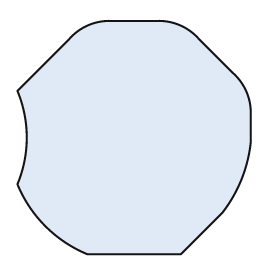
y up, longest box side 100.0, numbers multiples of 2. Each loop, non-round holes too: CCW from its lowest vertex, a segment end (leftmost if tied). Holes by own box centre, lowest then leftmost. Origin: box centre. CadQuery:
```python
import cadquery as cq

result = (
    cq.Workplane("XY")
    .moveTo(-20.0, -50.0)
    .lineTo(20.0, -50.0)
    .lineTo(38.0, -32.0)
    .threePointArc((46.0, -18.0), (50.0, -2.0))
    .lineTo(50.0, 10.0)
    .threePointArc((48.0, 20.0), (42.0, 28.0))
    .lineTo(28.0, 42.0)
    .threePointArc((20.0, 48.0), (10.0, 50.0))
    .lineTo(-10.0, 50.0)
    .threePointArc((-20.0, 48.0), (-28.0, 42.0))
    .lineTo(-50.0, 20.0)
    .threePointArc((-46.0, 0.0), (-50.0, -20.0))
    .threePointArc((-38.0, -38.0), (-20.0, -50.0))
    .close()
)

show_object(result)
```